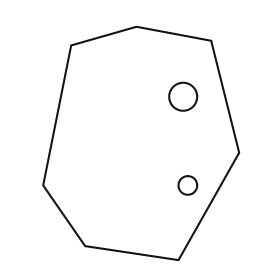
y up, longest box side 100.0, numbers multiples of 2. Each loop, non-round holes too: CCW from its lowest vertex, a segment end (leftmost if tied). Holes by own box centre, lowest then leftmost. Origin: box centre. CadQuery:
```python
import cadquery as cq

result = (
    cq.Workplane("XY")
    .moveTo(16.0, -50.0)
    .lineTo(42.0, -4.0)
    .lineTo(30.0, 44.0)
    .lineTo(-2.0, 50.0)
    .lineTo(-30.0, 42.0)
    .lineTo(-42.0, -18.0)
    .lineTo(-24.0, -44.0)
    .close()
    .moveTo(20.0, -18.0)
    .circle(4.0)
    .moveTo(18.0, 20.0)
    .circle(6.0)
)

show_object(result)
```